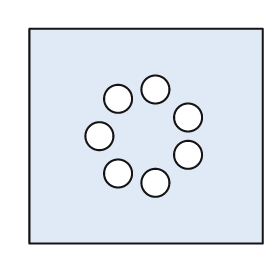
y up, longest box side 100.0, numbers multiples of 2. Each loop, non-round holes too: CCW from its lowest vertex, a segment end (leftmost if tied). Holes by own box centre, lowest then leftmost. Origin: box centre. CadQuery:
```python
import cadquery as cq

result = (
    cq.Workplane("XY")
    .moveTo(-50.0, -46.0)
    .lineTo(50.0, -46.0)
    .lineTo(50.0, 46.0)
    .lineTo(-50.0, 46.0)
    .close()
    .moveTo(4.0, -20.0)
    .circle(6.0)
    .moveTo(-12.0, -16.0)
    .circle(6.0)
    .moveTo(18.0, -8.0)
    .circle(6.0)
    .moveTo(-20.0, 0.0)
    .circle(6.0)
    .moveTo(18.0, 8.0)
    .circle(6.0)
    .moveTo(-12.0, 16.0)
    .circle(6.0)
    .moveTo(4.0, 20.0)
    .circle(6.0)
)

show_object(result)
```